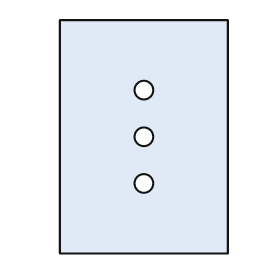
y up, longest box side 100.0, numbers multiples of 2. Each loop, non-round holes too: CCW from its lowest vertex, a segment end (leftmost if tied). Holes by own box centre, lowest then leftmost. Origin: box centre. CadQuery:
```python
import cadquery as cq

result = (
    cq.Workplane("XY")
    .moveTo(-36.0, -50.0)
    .lineTo(36.0, -50.0)
    .lineTo(36.0, 50.0)
    .lineTo(-36.0, 50.0)
    .close()
    .moveTo(0.0, -20.0)
    .circle(4.0)
    .moveTo(0.0, 0.0)
    .circle(4.0)
    .moveTo(0.0, 20.0)
    .circle(4.0)
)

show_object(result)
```